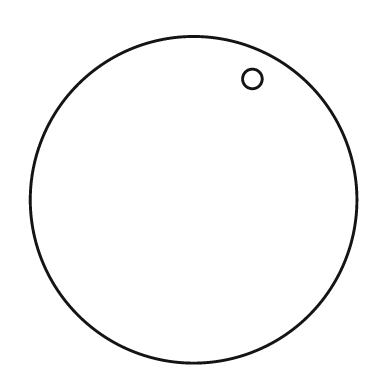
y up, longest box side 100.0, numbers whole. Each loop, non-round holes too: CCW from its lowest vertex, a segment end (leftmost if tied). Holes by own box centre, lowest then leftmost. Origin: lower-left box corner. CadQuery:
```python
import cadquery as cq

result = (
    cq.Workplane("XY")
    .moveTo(50.0, 50.0)
    .circle(50.0)
    .moveTo(68.0, 87.0)
    .circle(3.0)
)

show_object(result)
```